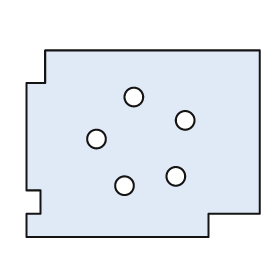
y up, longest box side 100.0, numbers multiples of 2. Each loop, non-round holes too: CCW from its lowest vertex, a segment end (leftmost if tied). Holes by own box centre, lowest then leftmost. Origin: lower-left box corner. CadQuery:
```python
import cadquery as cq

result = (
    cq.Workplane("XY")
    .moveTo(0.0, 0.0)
    .lineTo(78.0, 0.0)
    .lineTo(78.0, 10.0)
    .lineTo(100.0, 10.0)
    .lineTo(100.0, 80.0)
    .lineTo(8.0, 80.0)
    .lineTo(8.0, 66.0)
    .lineTo(0.0, 66.0)
    .lineTo(0.0, 20.0)
    .lineTo(6.0, 20.0)
    .lineTo(6.0, 10.0)
    .lineTo(0.0, 10.0)
    .close()
    .moveTo(42.0, 22.0)
    .circle(4.0)
    .moveTo(64.0, 26.0)
    .circle(4.0)
    .moveTo(30.0, 42.0)
    .circle(4.0)
    .moveTo(68.0, 50.0)
    .circle(4.0)
    .moveTo(46.0, 60.0)
    .circle(4.0)
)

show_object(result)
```